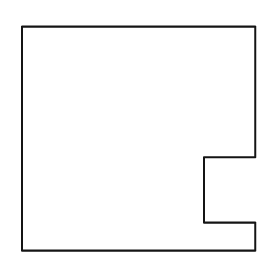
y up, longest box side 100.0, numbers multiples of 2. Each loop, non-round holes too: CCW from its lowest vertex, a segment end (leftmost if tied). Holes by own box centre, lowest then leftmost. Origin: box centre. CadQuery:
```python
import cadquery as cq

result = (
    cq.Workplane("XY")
    .moveTo(-50.0, -48.0)
    .lineTo(50.0, -48.0)
    .lineTo(50.0, -36.0)
    .lineTo(28.0, -36.0)
    .lineTo(28.0, -8.0)
    .lineTo(50.0, -8.0)
    .lineTo(50.0, 48.0)
    .lineTo(-50.0, 48.0)
    .close()
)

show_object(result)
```